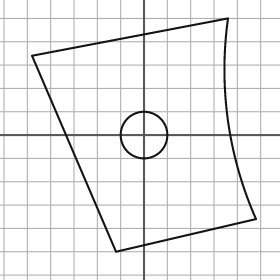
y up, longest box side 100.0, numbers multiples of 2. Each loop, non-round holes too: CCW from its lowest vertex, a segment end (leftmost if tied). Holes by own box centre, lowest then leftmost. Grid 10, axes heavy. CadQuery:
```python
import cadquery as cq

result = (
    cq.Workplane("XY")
    .moveTo(-12.0, -50.0)
    .lineTo(48.0, -36.0)
    .threePointArc((36.0, 6.0), (36.0, 50.0))
    .lineTo(-48.0, 34.0)
    .close()
    .moveTo(0.0, 0.0)
    .circle(10.0)
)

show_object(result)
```